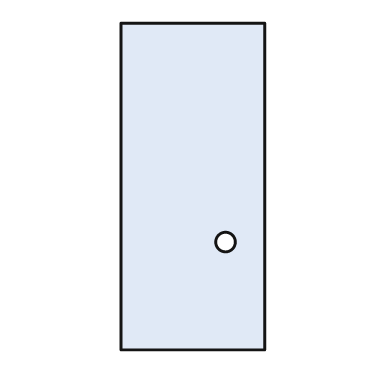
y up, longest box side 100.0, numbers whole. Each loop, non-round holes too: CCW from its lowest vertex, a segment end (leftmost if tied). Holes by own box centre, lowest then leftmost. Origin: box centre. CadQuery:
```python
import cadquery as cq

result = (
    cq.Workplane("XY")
    .moveTo(-22.0, -50.0)
    .lineTo(22.0, -50.0)
    .lineTo(22.0, 50.0)
    .lineTo(-22.0, 50.0)
    .close()
    .moveTo(10.0, -17.0)
    .circle(3.0)
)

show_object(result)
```